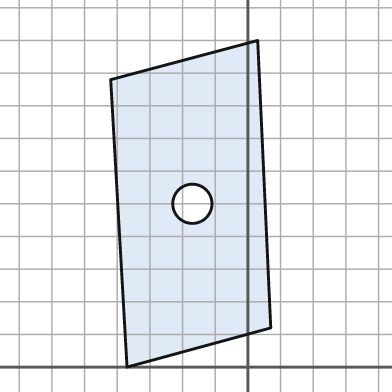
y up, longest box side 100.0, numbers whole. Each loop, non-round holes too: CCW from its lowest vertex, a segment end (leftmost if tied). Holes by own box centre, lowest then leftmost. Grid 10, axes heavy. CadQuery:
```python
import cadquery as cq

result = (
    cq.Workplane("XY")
    .moveTo(-37.0, 0.0)
    .lineTo(7.0, 12.0)
    .lineTo(3.0, 100.0)
    .lineTo(-42.0, 88.0)
    .close()
    .moveTo(-17.0, 50.0)
    .circle(6.0)
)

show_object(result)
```